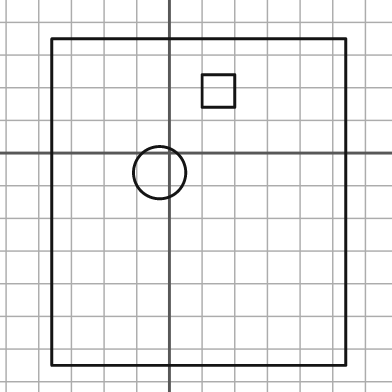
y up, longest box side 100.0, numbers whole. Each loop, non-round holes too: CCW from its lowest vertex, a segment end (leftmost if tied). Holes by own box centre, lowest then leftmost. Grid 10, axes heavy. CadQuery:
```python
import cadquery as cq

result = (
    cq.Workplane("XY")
    .moveTo(-36.0, -65.0)
    .lineTo(54.0, -65.0)
    .lineTo(54.0, 35.0)
    .lineTo(-36.0, 35.0)
    .close()
    .moveTo(-3.0, -6.0)
    .circle(8.0)
    .moveTo(10.0, 14.0)
    .lineTo(20.0, 14.0)
    .lineTo(20.0, 24.0)
    .lineTo(10.0, 24.0)
    .close()
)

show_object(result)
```